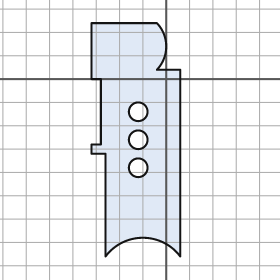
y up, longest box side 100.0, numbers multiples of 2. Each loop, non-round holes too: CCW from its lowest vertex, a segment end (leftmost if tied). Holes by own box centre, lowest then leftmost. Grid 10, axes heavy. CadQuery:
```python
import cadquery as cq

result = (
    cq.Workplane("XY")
    .moveTo(-26.0, -76.0)
    .threePointArc((-10.0, -68.0), (6.0, -76.0))
    .lineTo(6.0, 4.0)
    .lineTo(-4.0, 4.0)
    .threePointArc((0.0, 14.0), (-4.0, 24.0))
    .lineTo(-32.0, 24.0)
    .lineTo(-32.0, 0.0)
    .lineTo(-28.0, 0.0)
    .lineTo(-28.0, -28.0)
    .lineTo(-32.0, -28.0)
    .lineTo(-32.0, -32.0)
    .lineTo(-26.0, -32.0)
    .close()
    .moveTo(-12.0, -38.0)
    .circle(4.0)
    .moveTo(-12.0, -26.0)
    .circle(4.0)
    .moveTo(-12.0, -14.0)
    .circle(4.0)
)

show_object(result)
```